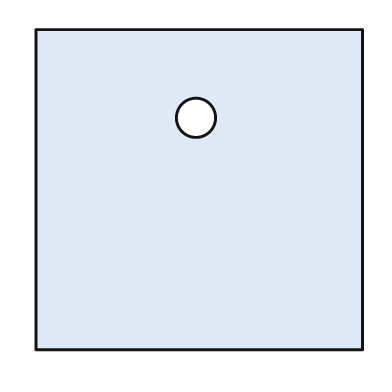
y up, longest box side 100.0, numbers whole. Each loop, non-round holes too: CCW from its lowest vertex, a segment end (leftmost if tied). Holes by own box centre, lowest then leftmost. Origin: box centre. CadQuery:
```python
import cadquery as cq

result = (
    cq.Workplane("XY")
    .moveTo(-50.0, -49.0)
    .lineTo(50.0, -49.0)
    .lineTo(50.0, 49.0)
    .lineTo(-50.0, 49.0)
    .close()
    .moveTo(-1.0, 22.0)
    .circle(6.0)
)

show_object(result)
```